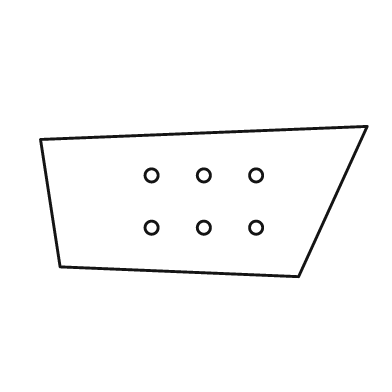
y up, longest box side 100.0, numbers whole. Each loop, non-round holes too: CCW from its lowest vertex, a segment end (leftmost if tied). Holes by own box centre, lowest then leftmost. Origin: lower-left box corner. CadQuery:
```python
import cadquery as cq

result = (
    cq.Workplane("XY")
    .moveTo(79.0, 0.0)
    .lineTo(100.0, 46.0)
    .lineTo(0.0, 42.0)
    .lineTo(6.0, 3.0)
    .close()
    .moveTo(34.0, 15.0)
    .circle(2.0)
    .moveTo(50.0, 15.0)
    .circle(2.0)
    .moveTo(66.0, 15.0)
    .circle(2.0)
    .moveTo(34.0, 31.0)
    .circle(2.0)
    .moveTo(50.0, 31.0)
    .circle(2.0)
    .moveTo(66.0, 31.0)
    .circle(2.0)
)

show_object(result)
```